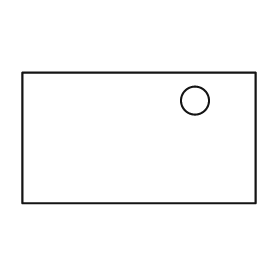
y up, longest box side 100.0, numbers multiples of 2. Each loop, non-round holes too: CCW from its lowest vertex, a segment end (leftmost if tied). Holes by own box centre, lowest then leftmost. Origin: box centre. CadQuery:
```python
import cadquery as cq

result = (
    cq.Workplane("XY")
    .moveTo(-50.0, -28.0)
    .lineTo(50.0, -28.0)
    .lineTo(50.0, 28.0)
    .lineTo(-50.0, 28.0)
    .close()
    .moveTo(24.0, 16.0)
    .circle(6.0)
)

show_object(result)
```